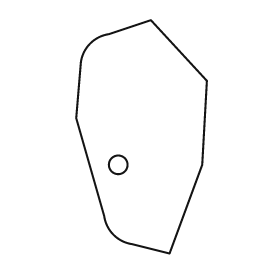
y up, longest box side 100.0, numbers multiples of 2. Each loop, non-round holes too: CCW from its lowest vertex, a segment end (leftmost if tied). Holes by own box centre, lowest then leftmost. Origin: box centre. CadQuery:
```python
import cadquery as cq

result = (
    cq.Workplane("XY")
    .moveTo(12.0, -50.0)
    .lineTo(26.0, -12.0)
    .lineTo(28.0, 24.0)
    .lineTo(4.0, 50.0)
    .lineTo(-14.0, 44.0)
    .threePointArc((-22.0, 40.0), (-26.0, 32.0))
    .lineTo(-28.0, 8.0)
    .lineTo(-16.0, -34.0)
    .threePointArc((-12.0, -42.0), (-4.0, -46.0))
    .close()
    .moveTo(-10.0, -12.0)
    .circle(4.0)
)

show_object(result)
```